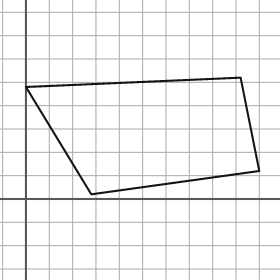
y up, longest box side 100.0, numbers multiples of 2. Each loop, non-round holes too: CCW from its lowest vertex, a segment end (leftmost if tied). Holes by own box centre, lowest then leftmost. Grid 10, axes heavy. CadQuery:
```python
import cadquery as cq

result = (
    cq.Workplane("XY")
    .moveTo(28.0, 2.0)
    .lineTo(100.0, 12.0)
    .lineTo(92.0, 52.0)
    .lineTo(0.0, 48.0)
    .close()
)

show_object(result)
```